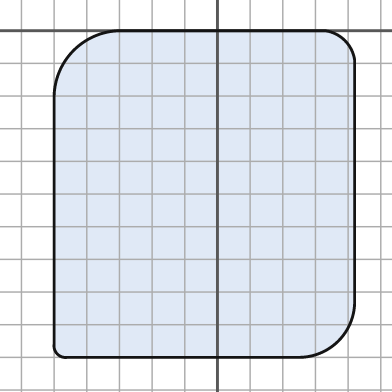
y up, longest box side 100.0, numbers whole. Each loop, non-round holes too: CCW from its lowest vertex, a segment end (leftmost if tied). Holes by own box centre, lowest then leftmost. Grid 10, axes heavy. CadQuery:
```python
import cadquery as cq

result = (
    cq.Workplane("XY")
    .moveTo(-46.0, -100.0)
    .lineTo(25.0, -100.0)
    .threePointArc((37.0, -95.0), (42.0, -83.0))
    .lineTo(42.0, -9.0)
    .threePointArc((39.0, -3.0), (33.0, 0.0))
    .lineTo(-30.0, 0.0)
    .threePointArc((-44.0, -6.0), (-50.0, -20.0))
    .lineTo(-50.0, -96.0)
    .threePointArc((-49.0, -99.0), (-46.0, -100.0))
    .close()
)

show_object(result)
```